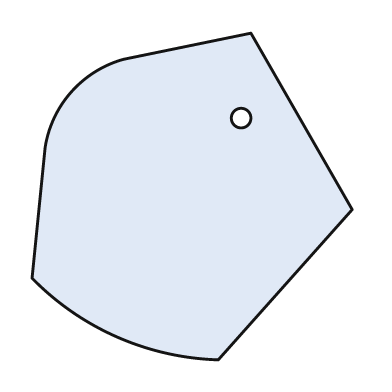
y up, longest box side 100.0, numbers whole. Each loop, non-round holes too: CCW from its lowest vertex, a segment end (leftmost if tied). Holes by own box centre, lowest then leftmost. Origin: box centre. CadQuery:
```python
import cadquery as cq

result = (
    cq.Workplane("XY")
    .moveTo(8.0, -50.0)
    .lineTo(49.0, -4.0)
    .lineTo(18.0, 50.0)
    .lineTo(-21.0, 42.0)
    .threePointArc((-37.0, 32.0), (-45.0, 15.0))
    .lineTo(-49.0, -25.0)
    .threePointArc((-23.0, -43.0), (8.0, -50.0))
    .close()
    .moveTo(15.0, 24.0)
    .circle(3.0)
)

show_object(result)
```